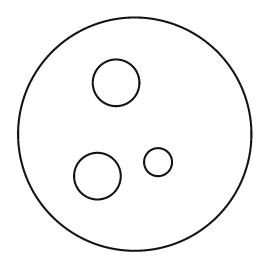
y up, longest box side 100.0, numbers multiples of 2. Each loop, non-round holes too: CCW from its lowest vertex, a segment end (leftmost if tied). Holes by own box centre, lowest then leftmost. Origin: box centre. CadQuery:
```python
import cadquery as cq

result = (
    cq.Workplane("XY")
    .moveTo(0.0, 0.0)
    .circle(50.0)
    .moveTo(-16.0, -18.0)
    .circle(10.0)
    .moveTo(10.0, -12.0)
    .circle(6.0)
    .moveTo(-8.0, 22.0)
    .circle(10.0)
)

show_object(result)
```